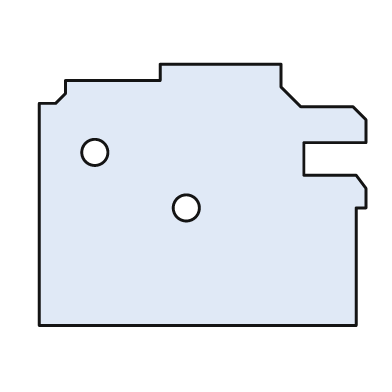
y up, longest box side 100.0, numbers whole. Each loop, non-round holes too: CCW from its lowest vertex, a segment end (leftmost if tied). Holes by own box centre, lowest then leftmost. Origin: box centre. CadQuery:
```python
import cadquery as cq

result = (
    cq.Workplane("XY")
    .moveTo(-50.0, -40.0)
    .lineTo(47.0, -40.0)
    .lineTo(47.0, -4.0)
    .lineTo(50.0, -4.0)
    .lineTo(50.0, 2.0)
    .lineTo(47.0, 6.0)
    .lineTo(31.0, 6.0)
    .lineTo(31.0, 16.0)
    .lineTo(50.0, 16.0)
    .lineTo(50.0, 23.0)
    .lineTo(46.0, 27.0)
    .lineTo(30.0, 27.0)
    .lineTo(24.0, 33.0)
    .lineTo(24.0, 40.0)
    .lineTo(-13.0, 40.0)
    .lineTo(-13.0, 35.0)
    .lineTo(-42.0, 35.0)
    .lineTo(-42.0, 31.0)
    .lineTo(-45.0, 28.0)
    .lineTo(-50.0, 28.0)
    .close()
    .moveTo(-5.0, -4.0)
    .circle(4.0)
    .moveTo(-33.0, 13.0)
    .circle(4.0)
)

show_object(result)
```